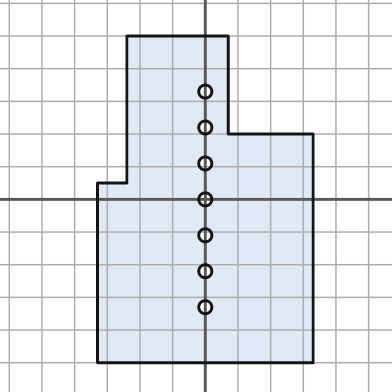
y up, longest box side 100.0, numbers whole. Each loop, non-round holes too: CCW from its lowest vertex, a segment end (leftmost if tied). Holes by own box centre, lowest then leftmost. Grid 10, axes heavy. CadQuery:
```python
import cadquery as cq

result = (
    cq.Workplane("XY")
    .moveTo(-33.0, -50.0)
    .lineTo(33.0, -50.0)
    .lineTo(33.0, 20.0)
    .lineTo(7.0, 20.0)
    .lineTo(7.0, 50.0)
    .lineTo(-24.0, 50.0)
    .lineTo(-24.0, 5.0)
    .lineTo(-33.0, 5.0)
    .close()
    .moveTo(0.0, -33.0)
    .circle(2.0)
    .moveTo(0.0, -22.0)
    .circle(2.0)
    .moveTo(0.0, -11.0)
    .circle(2.0)
    .moveTo(0.0, 0.0)
    .circle(2.0)
    .moveTo(0.0, 11.0)
    .circle(2.0)
    .moveTo(0.0, 22.0)
    .circle(2.0)
    .moveTo(0.0, 33.0)
    .circle(2.0)
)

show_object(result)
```